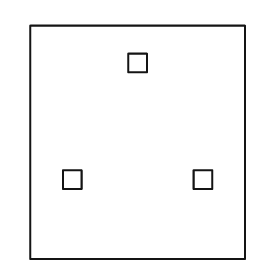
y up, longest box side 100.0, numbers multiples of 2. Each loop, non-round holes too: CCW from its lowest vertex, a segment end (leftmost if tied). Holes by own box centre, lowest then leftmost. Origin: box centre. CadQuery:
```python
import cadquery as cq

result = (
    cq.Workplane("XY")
    .moveTo(-46.0, -50.0)
    .lineTo(46.0, -50.0)
    .lineTo(46.0, 50.0)
    .lineTo(-46.0, 50.0)
    .close()
    .moveTo(-32.0, -20.0)
    .lineTo(-24.0, -20.0)
    .lineTo(-24.0, -12.0)
    .lineTo(-32.0, -12.0)
    .close()
    .moveTo(24.0, -20.0)
    .lineTo(32.0, -20.0)
    .lineTo(32.0, -12.0)
    .lineTo(24.0, -12.0)
    .close()
    .moveTo(-4.0, 30.0)
    .lineTo(4.0, 30.0)
    .lineTo(4.0, 38.0)
    .lineTo(-4.0, 38.0)
    .close()
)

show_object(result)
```